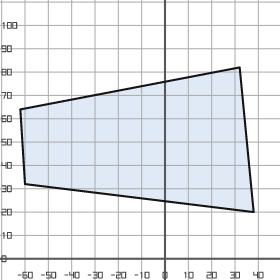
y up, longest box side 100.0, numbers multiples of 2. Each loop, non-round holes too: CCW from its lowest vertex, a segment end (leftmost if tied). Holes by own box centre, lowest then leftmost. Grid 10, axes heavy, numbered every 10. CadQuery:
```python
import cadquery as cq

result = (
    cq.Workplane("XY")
    .moveTo(38.0, 20.0)
    .lineTo(32.0, 82.0)
    .lineTo(-62.0, 64.0)
    .lineTo(-60.0, 32.0)
    .close()
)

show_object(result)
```